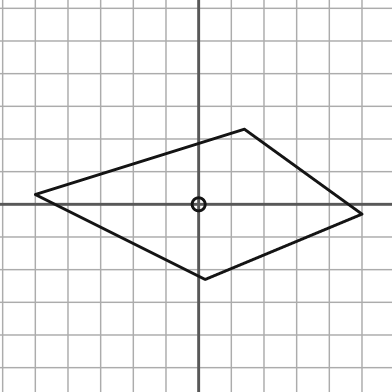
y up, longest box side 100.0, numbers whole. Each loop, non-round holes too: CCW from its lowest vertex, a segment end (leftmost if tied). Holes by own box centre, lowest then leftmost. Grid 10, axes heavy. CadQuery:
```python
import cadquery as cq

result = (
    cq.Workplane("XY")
    .moveTo(2.0, -23.0)
    .lineTo(50.0, -3.0)
    .lineTo(14.0, 23.0)
    .lineTo(-50.0, 3.0)
    .close()
    .moveTo(0.0, 0.0)
    .circle(2.0)
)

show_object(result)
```